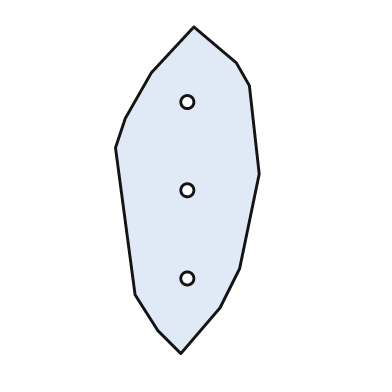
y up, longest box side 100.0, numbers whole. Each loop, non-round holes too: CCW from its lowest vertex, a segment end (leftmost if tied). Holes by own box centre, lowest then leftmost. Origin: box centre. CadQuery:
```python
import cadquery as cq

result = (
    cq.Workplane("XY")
    .moveTo(-2.0, -50.0)
    .lineTo(10.0, -36.0)
    .lineTo(16.0, -24.0)
    .lineTo(22.0, 5.0)
    .lineTo(19.0, 32.0)
    .lineTo(15.0, 39.0)
    .lineTo(2.0, 50.0)
    .lineTo(-11.0, 36.0)
    .lineTo(-19.0, 22.0)
    .lineTo(-22.0, 13.0)
    .lineTo(-16.0, -32.0)
    .lineTo(-9.0, -43.0)
    .close()
    .moveTo(0.0, -27.0)
    .circle(2.0)
    .moveTo(0.0, 0.0)
    .circle(2.0)
    .moveTo(0.0, 27.0)
    .circle(2.0)
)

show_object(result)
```